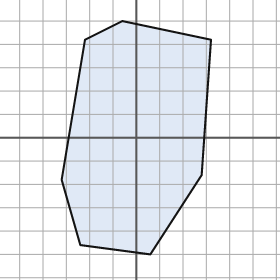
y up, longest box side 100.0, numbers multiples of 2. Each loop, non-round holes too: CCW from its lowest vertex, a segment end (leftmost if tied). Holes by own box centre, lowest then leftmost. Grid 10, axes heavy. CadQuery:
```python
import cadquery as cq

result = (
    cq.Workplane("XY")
    .moveTo(6.0, -50.0)
    .lineTo(28.0, -16.0)
    .lineTo(32.0, 42.0)
    .lineTo(-6.0, 50.0)
    .lineTo(-22.0, 42.0)
    .lineTo(-32.0, -18.0)
    .lineTo(-24.0, -46.0)
    .close()
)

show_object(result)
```